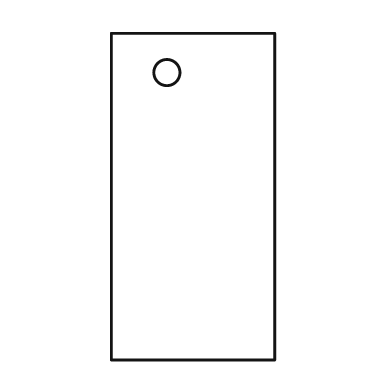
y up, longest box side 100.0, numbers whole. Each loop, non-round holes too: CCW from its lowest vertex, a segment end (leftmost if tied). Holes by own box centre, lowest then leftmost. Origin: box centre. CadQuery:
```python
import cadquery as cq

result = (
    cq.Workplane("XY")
    .moveTo(-25.0, -50.0)
    .lineTo(25.0, -50.0)
    .lineTo(25.0, 50.0)
    .lineTo(-25.0, 50.0)
    .close()
    .moveTo(-8.0, 38.0)
    .circle(4.0)
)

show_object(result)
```